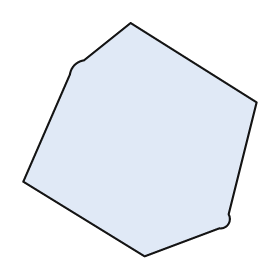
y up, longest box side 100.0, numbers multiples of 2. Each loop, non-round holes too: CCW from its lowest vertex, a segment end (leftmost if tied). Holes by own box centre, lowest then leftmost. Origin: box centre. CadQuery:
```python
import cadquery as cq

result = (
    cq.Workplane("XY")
    .moveTo(2.0, -50.0)
    .lineTo(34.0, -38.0)
    .threePointArc((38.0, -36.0), (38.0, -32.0))
    .lineTo(50.0, 16.0)
    .lineTo(-4.0, 50.0)
    .lineTo(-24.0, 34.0)
    .threePointArc((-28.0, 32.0), (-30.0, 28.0))
    .lineTo(-50.0, -18.0)
    .close()
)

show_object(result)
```